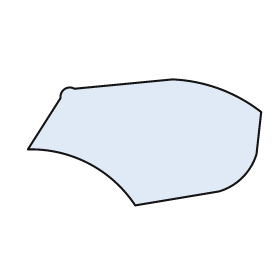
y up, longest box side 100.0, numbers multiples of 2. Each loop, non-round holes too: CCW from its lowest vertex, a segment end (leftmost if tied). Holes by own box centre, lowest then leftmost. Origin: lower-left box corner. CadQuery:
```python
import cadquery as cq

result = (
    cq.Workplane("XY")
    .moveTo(46.0, 0.0)
    .lineTo(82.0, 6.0)
    .threePointArc((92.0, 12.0), (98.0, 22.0))
    .lineTo(100.0, 40.0)
    .threePointArc((82.0, 50.0), (62.0, 54.0))
    .lineTo(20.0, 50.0)
    .threePointArc((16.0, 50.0), (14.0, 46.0))
    .lineTo(0.0, 24.0)
    .threePointArc((26.0, 18.0), (46.0, 0.0))
    .close()
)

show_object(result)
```